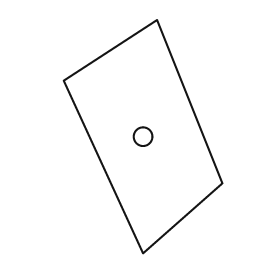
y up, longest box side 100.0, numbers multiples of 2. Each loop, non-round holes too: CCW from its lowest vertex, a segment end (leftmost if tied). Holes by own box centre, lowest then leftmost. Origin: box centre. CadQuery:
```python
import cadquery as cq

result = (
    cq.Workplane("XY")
    .moveTo(0.0, -50.0)
    .lineTo(34.0, -20.0)
    .lineTo(6.0, 50.0)
    .lineTo(-34.0, 24.0)
    .close()
    .moveTo(0.0, 0.0)
    .circle(4.0)
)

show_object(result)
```